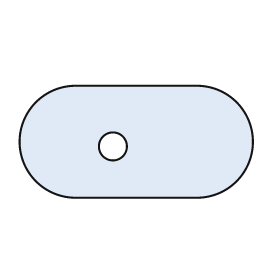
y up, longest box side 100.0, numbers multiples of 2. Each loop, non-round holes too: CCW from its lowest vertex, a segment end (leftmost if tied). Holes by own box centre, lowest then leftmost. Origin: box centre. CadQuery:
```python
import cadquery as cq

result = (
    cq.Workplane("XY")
    .moveTo(-26.0, -24.0)
    .lineTo(26.0, -24.0)
    .threePointArc((50.0, 0.0), (26.0, 24.0))
    .lineTo(-26.0, 24.0)
    .threePointArc((-50.0, 0.0), (-26.0, -24.0))
    .close()
    .moveTo(-10.0, -2.0)
    .circle(6.0)
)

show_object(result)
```